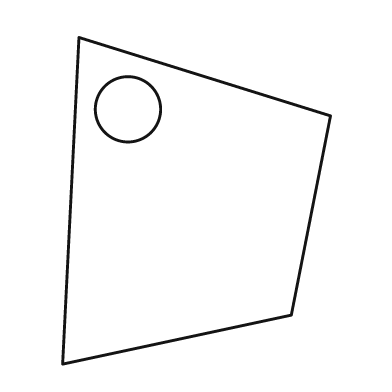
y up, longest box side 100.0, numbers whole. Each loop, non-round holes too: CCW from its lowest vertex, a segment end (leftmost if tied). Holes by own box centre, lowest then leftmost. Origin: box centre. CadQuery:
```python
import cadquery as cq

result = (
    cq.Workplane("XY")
    .moveTo(-41.0, -50.0)
    .lineTo(29.0, -35.0)
    .lineTo(41.0, 26.0)
    .lineTo(-36.0, 50.0)
    .close()
    .moveTo(-21.0, 28.0)
    .circle(10.0)
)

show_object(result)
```